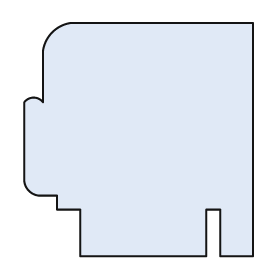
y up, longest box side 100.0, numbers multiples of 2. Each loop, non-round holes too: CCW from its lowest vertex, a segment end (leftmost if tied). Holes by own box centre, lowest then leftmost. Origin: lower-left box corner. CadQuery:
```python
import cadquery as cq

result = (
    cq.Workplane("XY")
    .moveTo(24.0, 0.0)
    .lineTo(78.0, 0.0)
    .lineTo(78.0, 20.0)
    .lineTo(84.0, 20.0)
    .lineTo(84.0, 0.0)
    .lineTo(98.0, 0.0)
    .lineTo(98.0, 100.0)
    .lineTo(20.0, 100.0)
    .threePointArc((12.0, 96.0), (8.0, 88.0))
    .lineTo(8.0, 66.0)
    .threePointArc((4.0, 68.0), (0.0, 66.0))
    .lineTo(0.0, 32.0)
    .threePointArc((2.0, 28.0), (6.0, 26.0))
    .lineTo(14.0, 26.0)
    .lineTo(14.0, 20.0)
    .lineTo(24.0, 20.0)
    .close()
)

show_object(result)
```